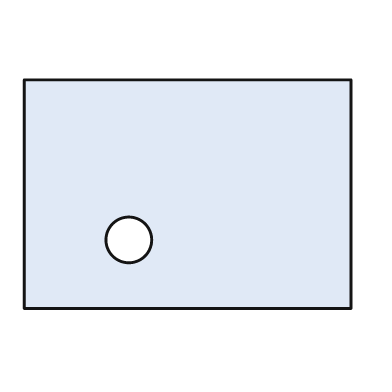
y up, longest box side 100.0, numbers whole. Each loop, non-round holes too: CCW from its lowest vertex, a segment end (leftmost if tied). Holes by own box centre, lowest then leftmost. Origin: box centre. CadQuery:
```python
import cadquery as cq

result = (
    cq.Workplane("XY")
    .moveTo(-50.0, -35.0)
    .lineTo(50.0, -35.0)
    .lineTo(50.0, 35.0)
    .lineTo(-50.0, 35.0)
    .close()
    .moveTo(-18.0, -14.0)
    .circle(7.0)
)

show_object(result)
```